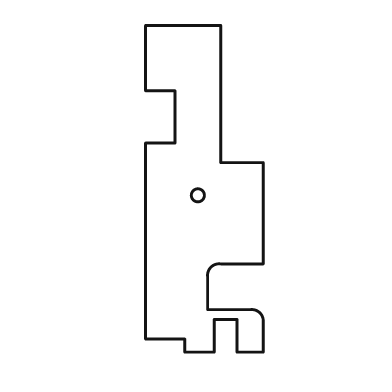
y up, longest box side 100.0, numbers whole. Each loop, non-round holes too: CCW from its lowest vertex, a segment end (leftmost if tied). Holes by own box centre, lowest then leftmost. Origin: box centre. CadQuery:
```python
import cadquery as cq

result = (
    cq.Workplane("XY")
    .moveTo(-6.0, -50.0)
    .lineTo(3.0, -50.0)
    .lineTo(3.0, -40.0)
    .lineTo(10.0, -40.0)
    .lineTo(10.0, -50.0)
    .lineTo(18.0, -50.0)
    .lineTo(18.0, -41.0)
    .threePointArc((17.0, -38.0), (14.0, -37.0))
    .lineTo(1.0, -37.0)
    .lineTo(1.0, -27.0)
    .threePointArc((2.0, -24.0), (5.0, -23.0))
    .lineTo(18.0, -23.0)
    .lineTo(18.0, 8.0)
    .lineTo(5.0, 8.0)
    .lineTo(5.0, 50.0)
    .lineTo(-18.0, 50.0)
    .lineTo(-18.0, 30.0)
    .lineTo(-9.0, 30.0)
    .lineTo(-9.0, 14.0)
    .lineTo(-18.0, 14.0)
    .lineTo(-18.0, -46.0)
    .lineTo(-6.0, -46.0)
    .close()
    .moveTo(-2.0, -2.0)
    .circle(2.0)
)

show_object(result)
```